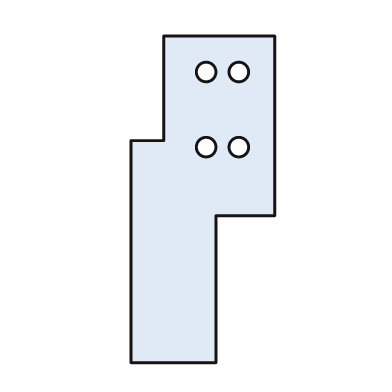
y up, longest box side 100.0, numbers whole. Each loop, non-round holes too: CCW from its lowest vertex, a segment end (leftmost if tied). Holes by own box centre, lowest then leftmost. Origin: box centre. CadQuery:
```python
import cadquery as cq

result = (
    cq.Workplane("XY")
    .moveTo(-22.0, -50.0)
    .lineTo(4.0, -50.0)
    .lineTo(4.0, -5.0)
    .lineTo(22.0, -5.0)
    .lineTo(22.0, 50.0)
    .lineTo(-12.0, 50.0)
    .lineTo(-12.0, 18.0)
    .lineTo(-22.0, 18.0)
    .close()
    .moveTo(1.0, 16.0)
    .circle(3.0)
    .moveTo(11.0, 16.0)
    .circle(3.0)
    .moveTo(1.0, 39.0)
    .circle(3.0)
    .moveTo(11.0, 39.0)
    .circle(3.0)
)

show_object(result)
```